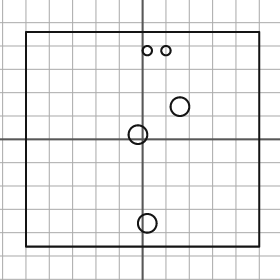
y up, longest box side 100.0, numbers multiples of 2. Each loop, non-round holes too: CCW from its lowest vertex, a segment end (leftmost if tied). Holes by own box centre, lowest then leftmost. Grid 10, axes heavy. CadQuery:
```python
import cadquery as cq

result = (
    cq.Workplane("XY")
    .moveTo(-50.0, -46.0)
    .lineTo(50.0, -46.0)
    .lineTo(50.0, 46.0)
    .lineTo(-50.0, 46.0)
    .close()
    .moveTo(2.0, -36.0)
    .circle(4.0)
    .moveTo(-2.0, 2.0)
    .circle(4.0)
    .moveTo(16.0, 14.0)
    .circle(4.0)
    .moveTo(2.0, 38.0)
    .circle(2.0)
    .moveTo(10.0, 38.0)
    .circle(2.0)
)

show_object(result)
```